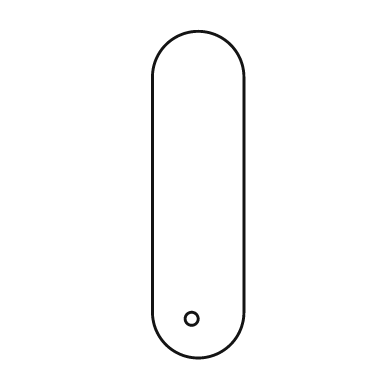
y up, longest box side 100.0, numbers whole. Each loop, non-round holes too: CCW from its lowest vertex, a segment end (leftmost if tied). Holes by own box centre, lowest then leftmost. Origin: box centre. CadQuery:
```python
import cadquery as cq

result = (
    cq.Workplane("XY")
    .moveTo(-14.0, -36.0)
    .threePointArc((0.0, -50.0), (14.0, -36.0))
    .lineTo(14.0, 36.0)
    .threePointArc((0.0, 50.0), (-14.0, 36.0))
    .close()
    .moveTo(-2.0, -38.0)
    .circle(2.0)
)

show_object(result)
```